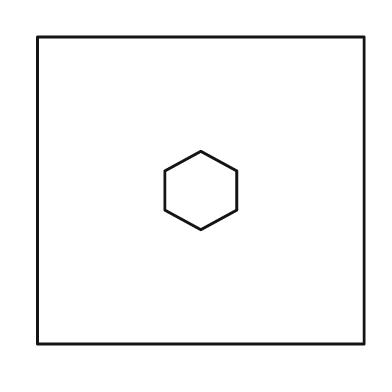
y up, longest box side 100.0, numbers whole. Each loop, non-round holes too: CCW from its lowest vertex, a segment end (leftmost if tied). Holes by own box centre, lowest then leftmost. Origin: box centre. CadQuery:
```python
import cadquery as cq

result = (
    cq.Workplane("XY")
    .moveTo(-50.0, -47.0)
    .lineTo(50.0, -47.0)
    .lineTo(50.0, 47.0)
    .lineTo(-50.0, 47.0)
    .close()
    .moveTo(0.0, -12.0)
    .lineTo(11.0, -6.0)
    .lineTo(11.0, 6.0)
    .lineTo(0.0, 12.0)
    .lineTo(-11.0, 6.0)
    .lineTo(-11.0, -6.0)
    .close()
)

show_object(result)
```